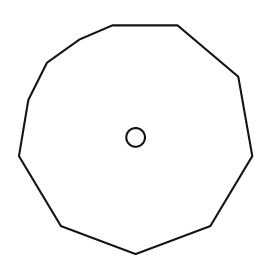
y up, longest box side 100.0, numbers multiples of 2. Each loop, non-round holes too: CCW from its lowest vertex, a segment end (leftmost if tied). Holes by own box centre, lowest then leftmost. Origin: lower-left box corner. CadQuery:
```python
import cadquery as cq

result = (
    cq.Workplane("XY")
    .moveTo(50.0, 0.0)
    .lineTo(82.0, 12.0)
    .lineTo(100.0, 42.0)
    .lineTo(94.0, 76.0)
    .lineTo(68.0, 98.0)
    .lineTo(40.0, 98.0)
    .lineTo(26.0, 92.0)
    .lineTo(12.0, 82.0)
    .lineTo(4.0, 66.0)
    .lineTo(0.0, 42.0)
    .lineTo(18.0, 12.0)
    .close()
    .moveTo(50.0, 50.0)
    .circle(4.0)
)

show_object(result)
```